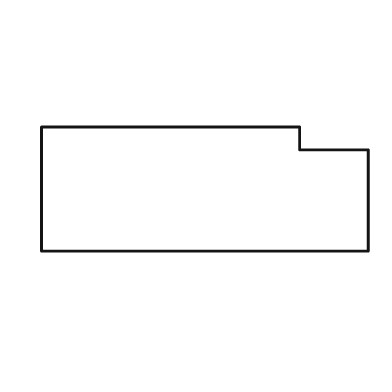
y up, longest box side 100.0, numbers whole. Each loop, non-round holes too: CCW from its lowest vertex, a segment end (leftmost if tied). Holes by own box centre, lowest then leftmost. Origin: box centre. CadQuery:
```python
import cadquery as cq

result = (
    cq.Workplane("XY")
    .moveTo(-50.0, -19.0)
    .lineTo(50.0, -19.0)
    .lineTo(50.0, 12.0)
    .lineTo(29.0, 12.0)
    .lineTo(29.0, 19.0)
    .lineTo(-50.0, 19.0)
    .close()
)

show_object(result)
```